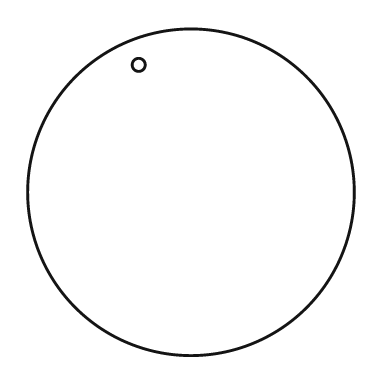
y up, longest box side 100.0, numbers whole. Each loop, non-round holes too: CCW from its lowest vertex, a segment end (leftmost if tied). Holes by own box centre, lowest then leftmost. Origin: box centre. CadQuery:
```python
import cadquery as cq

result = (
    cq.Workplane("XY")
    .moveTo(0.0, 0.0)
    .circle(50.0)
    .moveTo(-16.0, 39.0)
    .circle(2.0)
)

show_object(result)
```